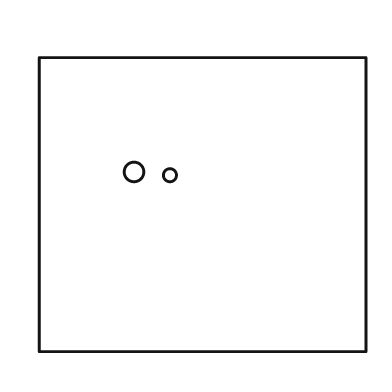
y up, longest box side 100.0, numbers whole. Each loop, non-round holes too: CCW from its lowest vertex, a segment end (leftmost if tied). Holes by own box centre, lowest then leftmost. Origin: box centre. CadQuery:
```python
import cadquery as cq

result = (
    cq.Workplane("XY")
    .moveTo(-50.0, -45.0)
    .lineTo(50.0, -45.0)
    .lineTo(50.0, 45.0)
    .lineTo(-50.0, 45.0)
    .close()
    .moveTo(-10.0, 9.0)
    .circle(2.0)
    .moveTo(-21.0, 10.0)
    .circle(3.0)
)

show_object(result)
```